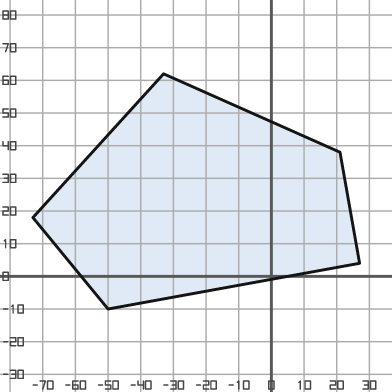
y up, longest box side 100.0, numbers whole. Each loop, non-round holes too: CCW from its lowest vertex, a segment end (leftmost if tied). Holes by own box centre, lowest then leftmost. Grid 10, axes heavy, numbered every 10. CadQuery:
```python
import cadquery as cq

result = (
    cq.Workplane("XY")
    .moveTo(-50.0, -10.0)
    .lineTo(27.0, 4.0)
    .lineTo(21.0, 38.0)
    .lineTo(-33.0, 62.0)
    .lineTo(-73.0, 18.0)
    .close()
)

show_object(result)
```